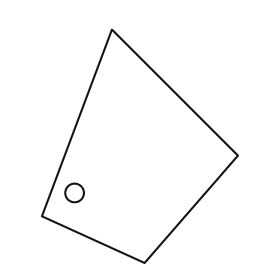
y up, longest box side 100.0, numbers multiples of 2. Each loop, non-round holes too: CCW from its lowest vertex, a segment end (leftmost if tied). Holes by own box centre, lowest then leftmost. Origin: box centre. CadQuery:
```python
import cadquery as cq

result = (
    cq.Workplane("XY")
    .moveTo(2.0, -50.0)
    .lineTo(42.0, -4.0)
    .lineTo(-12.0, 50.0)
    .lineTo(-42.0, -30.0)
    .close()
    .moveTo(-28.0, -20.0)
    .circle(4.0)
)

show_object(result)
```